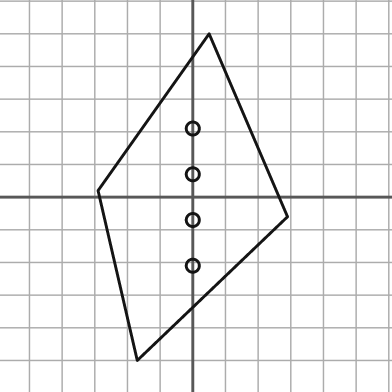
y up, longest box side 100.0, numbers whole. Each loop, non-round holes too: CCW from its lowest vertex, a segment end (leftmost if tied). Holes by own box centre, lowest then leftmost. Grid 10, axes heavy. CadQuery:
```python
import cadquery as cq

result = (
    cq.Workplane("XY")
    .moveTo(-17.0, -50.0)
    .lineTo(29.0, -6.0)
    .lineTo(5.0, 50.0)
    .lineTo(-29.0, 2.0)
    .close()
    .moveTo(0.0, -21.0)
    .circle(2.0)
    .moveTo(0.0, -7.0)
    .circle(2.0)
    .moveTo(0.0, 7.0)
    .circle(2.0)
    .moveTo(0.0, 21.0)
    .circle(2.0)
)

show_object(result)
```